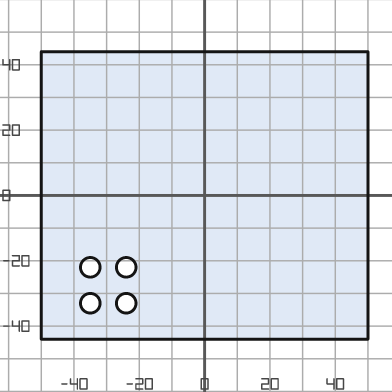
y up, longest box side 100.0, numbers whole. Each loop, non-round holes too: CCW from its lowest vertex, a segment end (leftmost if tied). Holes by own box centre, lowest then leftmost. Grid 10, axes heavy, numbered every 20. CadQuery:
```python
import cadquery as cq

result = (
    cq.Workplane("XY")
    .moveTo(-50.0, -44.0)
    .lineTo(50.0, -44.0)
    .lineTo(50.0, 44.0)
    .lineTo(-50.0, 44.0)
    .close()
    .moveTo(-35.0, -33.0)
    .circle(3.0)
    .moveTo(-24.0, -33.0)
    .circle(3.0)
    .moveTo(-35.0, -22.0)
    .circle(3.0)
    .moveTo(-24.0, -22.0)
    .circle(3.0)
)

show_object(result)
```